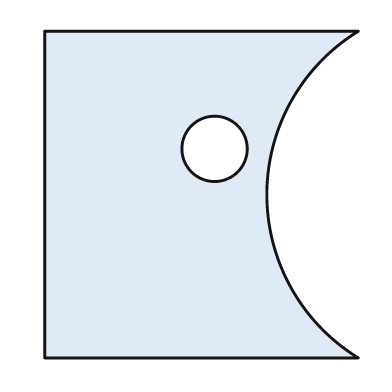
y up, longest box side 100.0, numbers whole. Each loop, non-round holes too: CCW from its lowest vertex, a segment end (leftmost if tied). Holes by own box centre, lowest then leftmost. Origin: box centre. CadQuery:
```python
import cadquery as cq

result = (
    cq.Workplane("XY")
    .moveTo(-48.0, -50.0)
    .lineTo(48.0, -50.0)
    .threePointArc((20.0, 0.0), (48.0, 50.0))
    .lineTo(-48.0, 50.0)
    .close()
    .moveTo(4.0, 14.0)
    .circle(10.0)
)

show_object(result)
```